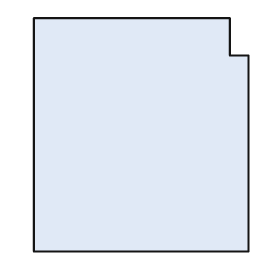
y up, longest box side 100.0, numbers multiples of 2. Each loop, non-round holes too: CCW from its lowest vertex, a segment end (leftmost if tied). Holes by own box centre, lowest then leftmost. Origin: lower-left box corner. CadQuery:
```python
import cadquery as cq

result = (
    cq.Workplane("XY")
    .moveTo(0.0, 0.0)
    .lineTo(92.0, 0.0)
    .lineTo(92.0, 84.0)
    .lineTo(84.0, 84.0)
    .lineTo(84.0, 100.0)
    .lineTo(0.0, 100.0)
    .close()
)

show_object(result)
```